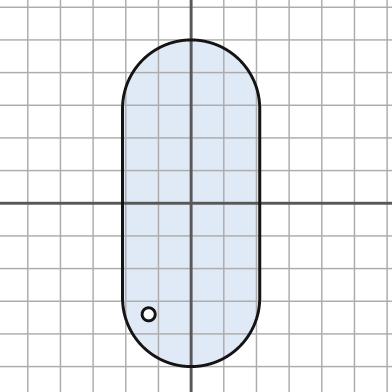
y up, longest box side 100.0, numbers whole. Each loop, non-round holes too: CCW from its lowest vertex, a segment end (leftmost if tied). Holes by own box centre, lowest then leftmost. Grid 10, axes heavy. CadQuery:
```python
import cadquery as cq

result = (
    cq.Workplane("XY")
    .moveTo(-21.0, -29.0)
    .threePointArc((0.0, -50.0), (21.0, -29.0))
    .lineTo(21.0, 29.0)
    .threePointArc((0.0, 50.0), (-21.0, 29.0))
    .close()
    .moveTo(-13.0, -34.0)
    .circle(2.0)
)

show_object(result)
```